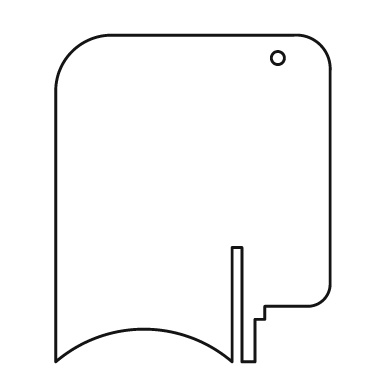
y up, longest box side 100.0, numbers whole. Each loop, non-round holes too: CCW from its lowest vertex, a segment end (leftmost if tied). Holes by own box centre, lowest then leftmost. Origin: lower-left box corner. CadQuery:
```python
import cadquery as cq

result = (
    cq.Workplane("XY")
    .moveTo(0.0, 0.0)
    .threePointArc((27.0, 10.0), (54.0, 0.0))
    .lineTo(54.0, 35.0)
    .lineTo(57.0, 35.0)
    .lineTo(57.0, 0.0)
    .lineTo(61.0, 0.0)
    .lineTo(61.0, 13.0)
    .lineTo(64.0, 13.0)
    .lineTo(64.0, 17.0)
    .lineTo(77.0, 17.0)
    .threePointArc((82.0, 19.0), (84.0, 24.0))
    .lineTo(84.0, 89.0)
    .threePointArc((81.0, 97.0), (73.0, 100.0))
    .lineTo(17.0, 100.0)
    .threePointArc((5.0, 95.0), (0.0, 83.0))
    .close()
    .moveTo(68.0, 93.0)
    .circle(2.0)
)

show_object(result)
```